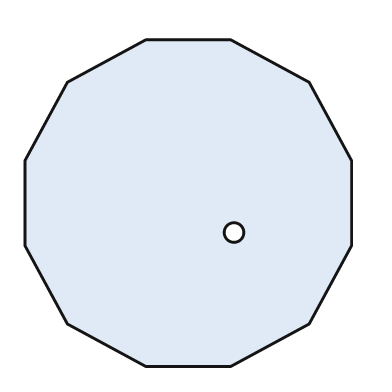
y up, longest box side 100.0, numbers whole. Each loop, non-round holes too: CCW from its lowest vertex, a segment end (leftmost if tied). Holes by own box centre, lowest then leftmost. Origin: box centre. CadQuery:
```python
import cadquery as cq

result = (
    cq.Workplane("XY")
    .moveTo(-13.0, -50.0)
    .lineTo(13.0, -50.0)
    .lineTo(37.0, -37.0)
    .lineTo(50.0, -13.0)
    .lineTo(50.0, 13.0)
    .lineTo(37.0, 37.0)
    .lineTo(13.0, 50.0)
    .lineTo(-13.0, 50.0)
    .lineTo(-37.0, 37.0)
    .lineTo(-50.0, 13.0)
    .lineTo(-50.0, -13.0)
    .lineTo(-37.0, -37.0)
    .close()
    .moveTo(14.0, -9.0)
    .circle(3.0)
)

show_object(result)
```